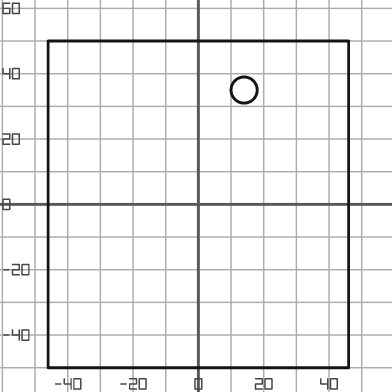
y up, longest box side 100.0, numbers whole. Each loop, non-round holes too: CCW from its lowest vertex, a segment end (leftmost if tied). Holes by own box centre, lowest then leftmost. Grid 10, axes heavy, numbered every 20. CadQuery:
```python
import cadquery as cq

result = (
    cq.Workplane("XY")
    .moveTo(-46.0, -50.0)
    .lineTo(46.0, -50.0)
    .lineTo(46.0, 50.0)
    .lineTo(-46.0, 50.0)
    .close()
    .moveTo(14.0, 35.0)
    .circle(4.0)
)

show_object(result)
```